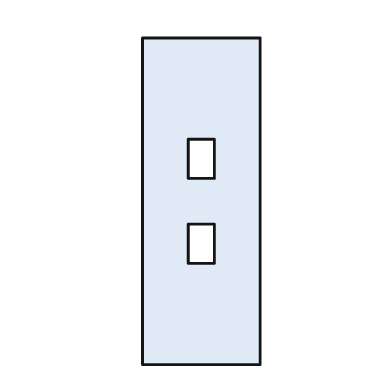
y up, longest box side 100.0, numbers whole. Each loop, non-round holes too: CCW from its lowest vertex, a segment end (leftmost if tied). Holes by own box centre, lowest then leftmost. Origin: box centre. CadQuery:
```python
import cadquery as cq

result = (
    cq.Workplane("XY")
    .moveTo(-18.0, -50.0)
    .lineTo(18.0, -50.0)
    .lineTo(18.0, 50.0)
    .lineTo(-18.0, 50.0)
    .close()
    .moveTo(-4.0, -19.0)
    .lineTo(4.0, -19.0)
    .lineTo(4.0, -7.0)
    .lineTo(-4.0, -7.0)
    .close()
    .moveTo(-4.0, 7.0)
    .lineTo(4.0, 7.0)
    .lineTo(4.0, 19.0)
    .lineTo(-4.0, 19.0)
    .close()
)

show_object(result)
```